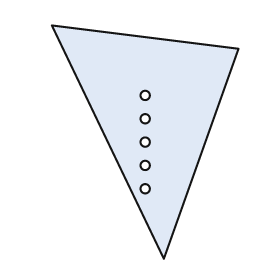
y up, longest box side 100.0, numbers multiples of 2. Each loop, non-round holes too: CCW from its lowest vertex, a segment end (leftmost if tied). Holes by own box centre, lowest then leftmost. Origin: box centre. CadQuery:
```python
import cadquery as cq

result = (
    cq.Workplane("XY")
    .moveTo(8.0, -50.0)
    .lineTo(40.0, 40.0)
    .lineTo(-40.0, 50.0)
    .close()
    .moveTo(0.0, -20.0)
    .circle(2.0)
    .moveTo(0.0, -10.0)
    .circle(2.0)
    .moveTo(0.0, 0.0)
    .circle(2.0)
    .moveTo(0.0, 10.0)
    .circle(2.0)
    .moveTo(0.0, 20.0)
    .circle(2.0)
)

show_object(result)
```